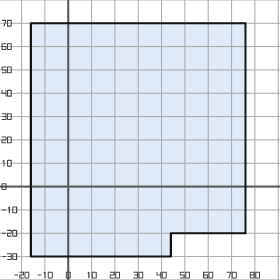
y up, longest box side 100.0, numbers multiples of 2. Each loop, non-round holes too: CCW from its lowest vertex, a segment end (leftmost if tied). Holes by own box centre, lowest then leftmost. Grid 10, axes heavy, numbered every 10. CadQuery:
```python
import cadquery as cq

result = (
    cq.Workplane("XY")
    .moveTo(-16.0, -30.0)
    .lineTo(44.0, -30.0)
    .lineTo(44.0, -20.0)
    .lineTo(76.0, -20.0)
    .lineTo(76.0, 70.0)
    .lineTo(-16.0, 70.0)
    .close()
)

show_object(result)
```